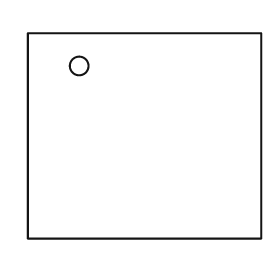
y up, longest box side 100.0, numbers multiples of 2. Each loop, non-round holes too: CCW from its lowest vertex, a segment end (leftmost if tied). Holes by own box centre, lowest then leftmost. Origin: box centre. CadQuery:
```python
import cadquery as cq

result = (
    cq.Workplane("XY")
    .moveTo(-50.0, -44.0)
    .lineTo(50.0, -44.0)
    .lineTo(50.0, 44.0)
    .lineTo(-50.0, 44.0)
    .close()
    .moveTo(-28.0, 30.0)
    .circle(4.0)
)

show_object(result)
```